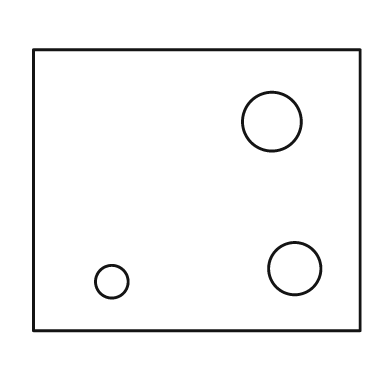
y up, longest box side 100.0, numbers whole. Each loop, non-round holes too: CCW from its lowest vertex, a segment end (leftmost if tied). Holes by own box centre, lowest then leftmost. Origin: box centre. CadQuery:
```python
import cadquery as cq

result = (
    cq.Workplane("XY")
    .moveTo(-50.0, -43.0)
    .lineTo(50.0, -43.0)
    .lineTo(50.0, 43.0)
    .lineTo(-50.0, 43.0)
    .close()
    .moveTo(-26.0, -28.0)
    .circle(5.0)
    .moveTo(30.0, -24.0)
    .circle(8.0)
    .moveTo(23.0, 21.0)
    .circle(9.0)
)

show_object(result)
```